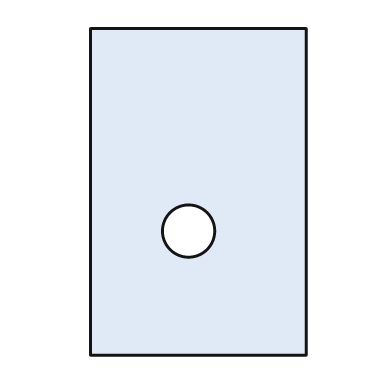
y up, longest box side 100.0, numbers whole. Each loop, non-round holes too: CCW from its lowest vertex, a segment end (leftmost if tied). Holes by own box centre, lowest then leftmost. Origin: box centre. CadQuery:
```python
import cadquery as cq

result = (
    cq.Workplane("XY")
    .moveTo(-33.0, -50.0)
    .lineTo(33.0, -50.0)
    .lineTo(33.0, 50.0)
    .lineTo(-33.0, 50.0)
    .close()
    .moveTo(-3.0, -12.0)
    .circle(8.0)
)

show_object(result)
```